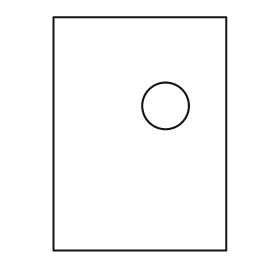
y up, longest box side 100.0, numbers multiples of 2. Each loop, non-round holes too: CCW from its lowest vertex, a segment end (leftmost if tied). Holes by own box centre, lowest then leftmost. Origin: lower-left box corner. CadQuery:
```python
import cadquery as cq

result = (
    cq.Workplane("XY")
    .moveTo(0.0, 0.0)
    .lineTo(74.0, 0.0)
    .lineTo(74.0, 100.0)
    .lineTo(0.0, 100.0)
    .close()
    .moveTo(48.0, 62.0)
    .circle(10.0)
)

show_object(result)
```